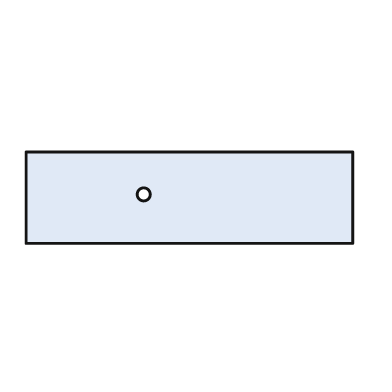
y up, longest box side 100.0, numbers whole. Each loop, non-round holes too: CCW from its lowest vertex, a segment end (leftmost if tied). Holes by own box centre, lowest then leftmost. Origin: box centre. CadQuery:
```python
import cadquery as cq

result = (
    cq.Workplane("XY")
    .moveTo(-50.0, -14.0)
    .lineTo(50.0, -14.0)
    .lineTo(50.0, 14.0)
    .lineTo(-50.0, 14.0)
    .close()
    .moveTo(-14.0, 1.0)
    .circle(2.0)
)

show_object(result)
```